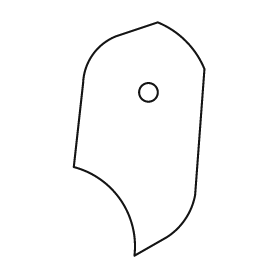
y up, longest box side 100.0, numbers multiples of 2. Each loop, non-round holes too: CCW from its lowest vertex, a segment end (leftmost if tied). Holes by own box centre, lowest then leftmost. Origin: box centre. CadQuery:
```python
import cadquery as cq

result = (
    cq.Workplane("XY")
    .moveTo(-2.0, -50.0)
    .lineTo(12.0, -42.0)
    .threePointArc((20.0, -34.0), (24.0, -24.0))
    .lineTo(28.0, 30.0)
    .threePointArc((20.0, 42.0), (8.0, 50.0))
    .lineTo(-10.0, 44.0)
    .threePointArc((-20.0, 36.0), (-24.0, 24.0))
    .lineTo(-28.0, -12.0)
    .threePointArc((-8.0, -26.0), (-2.0, -50.0))
    .close()
    .moveTo(4.0, 20.0)
    .circle(4.0)
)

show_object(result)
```